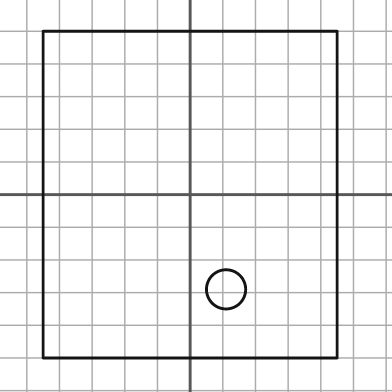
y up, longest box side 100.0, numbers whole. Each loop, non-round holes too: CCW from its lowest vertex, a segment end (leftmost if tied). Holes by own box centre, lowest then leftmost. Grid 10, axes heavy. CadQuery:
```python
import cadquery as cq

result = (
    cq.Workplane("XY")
    .moveTo(-45.0, -50.0)
    .lineTo(45.0, -50.0)
    .lineTo(45.0, 50.0)
    .lineTo(-45.0, 50.0)
    .close()
    .moveTo(11.0, -29.0)
    .circle(6.0)
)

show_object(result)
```